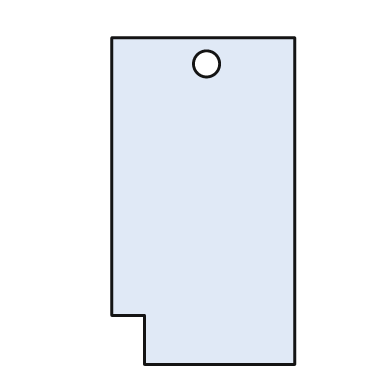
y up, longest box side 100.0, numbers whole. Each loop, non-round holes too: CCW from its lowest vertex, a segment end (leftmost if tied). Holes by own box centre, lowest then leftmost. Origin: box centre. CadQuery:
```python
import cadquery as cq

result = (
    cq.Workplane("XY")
    .moveTo(-18.0, -50.0)
    .lineTo(28.0, -50.0)
    .lineTo(28.0, 50.0)
    .lineTo(-28.0, 50.0)
    .lineTo(-28.0, -35.0)
    .lineTo(-18.0, -35.0)
    .close()
    .moveTo(1.0, 42.0)
    .circle(4.0)
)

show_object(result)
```